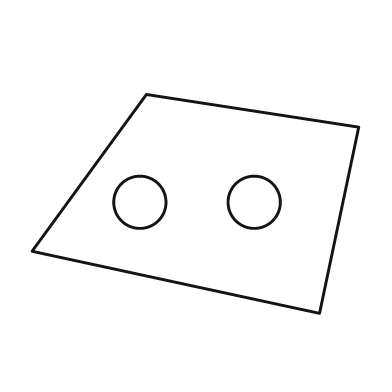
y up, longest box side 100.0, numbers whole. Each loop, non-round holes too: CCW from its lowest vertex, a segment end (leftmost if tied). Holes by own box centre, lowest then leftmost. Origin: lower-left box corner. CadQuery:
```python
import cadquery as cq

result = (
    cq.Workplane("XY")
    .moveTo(88.0, 0.0)
    .lineTo(100.0, 57.0)
    .lineTo(35.0, 67.0)
    .lineTo(0.0, 19.0)
    .close()
    .moveTo(33.0, 34.0)
    .circle(8.0)
    .moveTo(68.0, 34.0)
    .circle(8.0)
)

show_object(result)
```